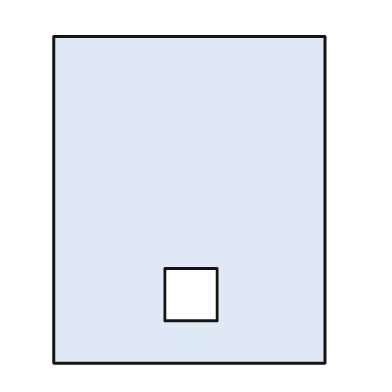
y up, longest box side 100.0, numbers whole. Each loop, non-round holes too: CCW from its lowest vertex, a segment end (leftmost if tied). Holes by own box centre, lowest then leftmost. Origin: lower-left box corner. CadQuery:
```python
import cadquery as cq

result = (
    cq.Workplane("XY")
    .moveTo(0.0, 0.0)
    .lineTo(83.0, 0.0)
    .lineTo(83.0, 100.0)
    .lineTo(0.0, 100.0)
    .close()
    .moveTo(34.0, 13.0)
    .lineTo(50.0, 13.0)
    .lineTo(50.0, 29.0)
    .lineTo(34.0, 29.0)
    .close()
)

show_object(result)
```